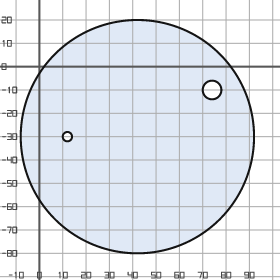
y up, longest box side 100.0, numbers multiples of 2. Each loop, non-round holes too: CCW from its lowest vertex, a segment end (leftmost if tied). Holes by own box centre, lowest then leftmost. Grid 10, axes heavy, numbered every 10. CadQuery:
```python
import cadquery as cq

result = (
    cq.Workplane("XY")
    .moveTo(42.0, -30.0)
    .circle(50.0)
    .moveTo(12.0, -30.0)
    .circle(2.0)
    .moveTo(74.0, -10.0)
    .circle(4.0)
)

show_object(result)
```